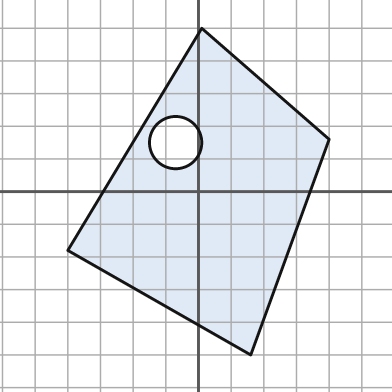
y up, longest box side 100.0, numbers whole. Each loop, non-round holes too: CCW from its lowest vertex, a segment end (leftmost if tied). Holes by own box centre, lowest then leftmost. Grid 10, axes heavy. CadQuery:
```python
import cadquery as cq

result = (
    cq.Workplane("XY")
    .moveTo(16.0, -50.0)
    .lineTo(40.0, 16.0)
    .lineTo(1.0, 50.0)
    .lineTo(-40.0, -18.0)
    .close()
    .moveTo(-7.0, 15.0)
    .circle(8.0)
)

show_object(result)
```